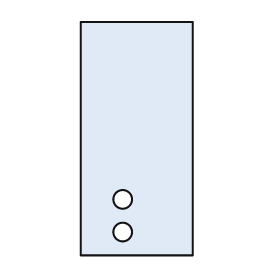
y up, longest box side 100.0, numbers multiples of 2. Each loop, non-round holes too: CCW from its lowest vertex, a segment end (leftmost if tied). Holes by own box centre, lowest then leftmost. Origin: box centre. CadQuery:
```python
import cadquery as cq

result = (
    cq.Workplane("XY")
    .moveTo(-24.0, -50.0)
    .lineTo(24.0, -50.0)
    .lineTo(24.0, 50.0)
    .lineTo(-24.0, 50.0)
    .close()
    .moveTo(-6.0, -40.0)
    .circle(4.0)
    .moveTo(-6.0, -26.0)
    .circle(4.0)
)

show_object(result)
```